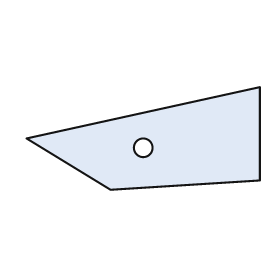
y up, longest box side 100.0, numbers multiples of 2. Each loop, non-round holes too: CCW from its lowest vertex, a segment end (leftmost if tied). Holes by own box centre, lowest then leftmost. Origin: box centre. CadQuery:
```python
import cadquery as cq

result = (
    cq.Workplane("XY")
    .moveTo(-14.0, -22.0)
    .lineTo(50.0, -18.0)
    .lineTo(50.0, 22.0)
    .lineTo(-50.0, 0.0)
    .close()
    .moveTo(0.0, -4.0)
    .circle(4.0)
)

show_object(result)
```